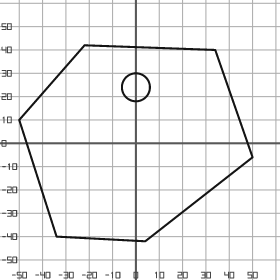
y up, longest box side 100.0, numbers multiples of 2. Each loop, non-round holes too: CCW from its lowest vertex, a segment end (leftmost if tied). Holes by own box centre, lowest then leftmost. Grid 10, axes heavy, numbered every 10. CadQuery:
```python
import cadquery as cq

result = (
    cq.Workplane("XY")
    .moveTo(4.0, -42.0)
    .lineTo(50.0, -6.0)
    .lineTo(34.0, 40.0)
    .lineTo(-22.0, 42.0)
    .lineTo(-50.0, 10.0)
    .lineTo(-34.0, -40.0)
    .close()
    .moveTo(0.0, 24.0)
    .circle(6.0)
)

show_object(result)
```